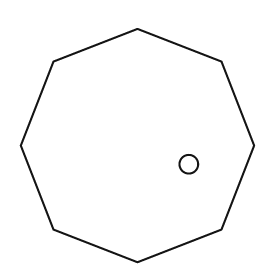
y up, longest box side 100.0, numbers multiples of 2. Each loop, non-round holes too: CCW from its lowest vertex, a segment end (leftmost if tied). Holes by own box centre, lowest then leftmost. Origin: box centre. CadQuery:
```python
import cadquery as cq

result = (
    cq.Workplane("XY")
    .moveTo(0.0, -50.0)
    .lineTo(36.0, -36.0)
    .lineTo(50.0, 0.0)
    .lineTo(36.0, 36.0)
    .lineTo(0.0, 50.0)
    .lineTo(-36.0, 36.0)
    .lineTo(-50.0, 0.0)
    .lineTo(-36.0, -36.0)
    .close()
    .moveTo(22.0, -8.0)
    .circle(4.0)
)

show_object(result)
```